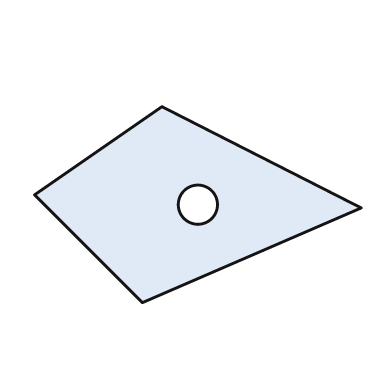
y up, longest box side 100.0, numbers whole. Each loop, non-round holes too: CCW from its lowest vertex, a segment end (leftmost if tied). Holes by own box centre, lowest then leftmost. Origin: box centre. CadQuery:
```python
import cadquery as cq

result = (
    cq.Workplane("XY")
    .moveTo(-17.0, -30.0)
    .lineTo(50.0, -1.0)
    .lineTo(-11.0, 30.0)
    .lineTo(-50.0, 3.0)
    .close()
    .moveTo(0.0, 0.0)
    .circle(6.0)
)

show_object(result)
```